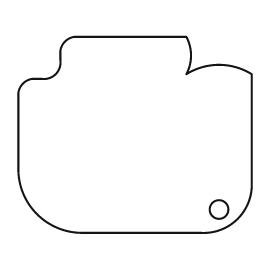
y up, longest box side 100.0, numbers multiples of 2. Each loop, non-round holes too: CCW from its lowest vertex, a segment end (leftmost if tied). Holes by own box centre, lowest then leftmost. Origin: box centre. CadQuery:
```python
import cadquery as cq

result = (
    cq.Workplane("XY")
    .moveTo(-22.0, -42.0)
    .lineTo(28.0, -42.0)
    .threePointArc((44.0, -36.0), (50.0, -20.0))
    .lineTo(50.0, 26.0)
    .threePointArc((36.0, 30.0), (22.0, 26.0))
    .threePointArc((24.0, 34.0), (22.0, 42.0))
    .lineTo(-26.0, 42.0)
    .threePointArc((-30.0, 40.0), (-32.0, 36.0))
    .lineTo(-32.0, 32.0)
    .threePointArc((-34.0, 26.0), (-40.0, 24.0))
    .lineTo(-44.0, 24.0)
    .threePointArc((-48.0, 22.0), (-50.0, 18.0))
    .lineTo(-50.0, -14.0)
    .threePointArc((-42.0, -34.0), (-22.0, -42.0))
    .close()
    .moveTo(36.0, -32.0)
    .circle(4.0)
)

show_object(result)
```